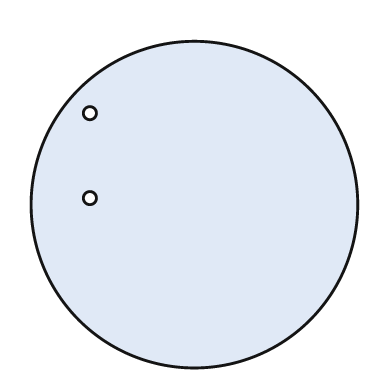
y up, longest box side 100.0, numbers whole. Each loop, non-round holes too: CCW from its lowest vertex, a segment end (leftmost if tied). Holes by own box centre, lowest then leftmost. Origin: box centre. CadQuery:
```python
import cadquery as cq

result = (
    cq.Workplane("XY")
    .moveTo(0.0, 0.0)
    .circle(50.0)
    .moveTo(-32.0, 2.0)
    .circle(2.0)
    .moveTo(-32.0, 28.0)
    .circle(2.0)
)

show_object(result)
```